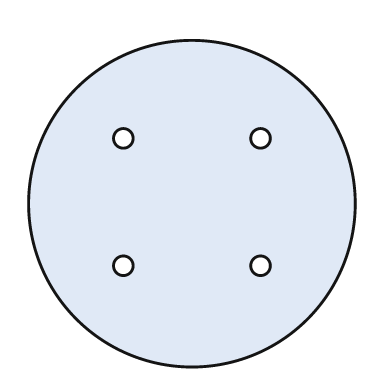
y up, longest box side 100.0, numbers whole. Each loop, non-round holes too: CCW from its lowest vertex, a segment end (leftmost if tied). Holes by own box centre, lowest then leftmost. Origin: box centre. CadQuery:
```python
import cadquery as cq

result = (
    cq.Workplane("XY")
    .moveTo(0.0, 0.0)
    .circle(50.0)
    .moveTo(-21.0, -19.0)
    .circle(3.0)
    .moveTo(21.0, -19.0)
    .circle(3.0)
    .moveTo(-21.0, 20.0)
    .circle(3.0)
    .moveTo(21.0, 20.0)
    .circle(3.0)
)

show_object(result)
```